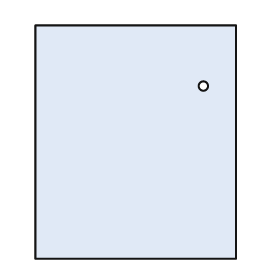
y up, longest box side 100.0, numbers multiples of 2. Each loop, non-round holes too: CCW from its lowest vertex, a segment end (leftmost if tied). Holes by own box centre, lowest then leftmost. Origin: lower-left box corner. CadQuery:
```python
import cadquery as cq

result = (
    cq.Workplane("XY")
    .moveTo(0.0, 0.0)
    .lineTo(86.0, 0.0)
    .lineTo(86.0, 100.0)
    .lineTo(0.0, 100.0)
    .close()
    .moveTo(72.0, 74.0)
    .circle(2.0)
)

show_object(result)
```